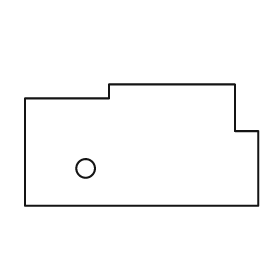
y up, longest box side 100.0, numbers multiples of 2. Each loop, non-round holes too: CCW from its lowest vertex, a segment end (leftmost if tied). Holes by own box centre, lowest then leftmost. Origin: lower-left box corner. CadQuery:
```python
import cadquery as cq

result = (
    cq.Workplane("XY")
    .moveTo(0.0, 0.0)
    .lineTo(100.0, 0.0)
    .lineTo(100.0, 32.0)
    .lineTo(90.0, 32.0)
    .lineTo(90.0, 52.0)
    .lineTo(36.0, 52.0)
    .lineTo(36.0, 46.0)
    .lineTo(0.0, 46.0)
    .close()
    .moveTo(26.0, 16.0)
    .circle(4.0)
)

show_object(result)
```